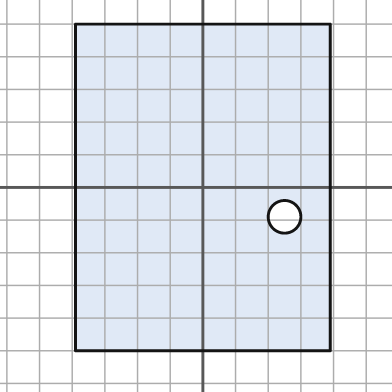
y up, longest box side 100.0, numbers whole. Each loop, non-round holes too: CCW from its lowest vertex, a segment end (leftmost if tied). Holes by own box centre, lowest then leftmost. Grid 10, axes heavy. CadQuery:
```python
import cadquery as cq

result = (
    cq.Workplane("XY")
    .moveTo(-39.0, -50.0)
    .lineTo(39.0, -50.0)
    .lineTo(39.0, 50.0)
    .lineTo(-39.0, 50.0)
    .close()
    .moveTo(25.0, -9.0)
    .circle(5.0)
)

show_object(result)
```